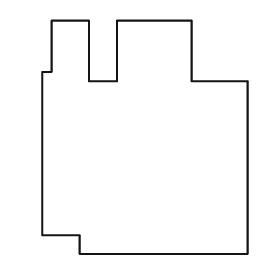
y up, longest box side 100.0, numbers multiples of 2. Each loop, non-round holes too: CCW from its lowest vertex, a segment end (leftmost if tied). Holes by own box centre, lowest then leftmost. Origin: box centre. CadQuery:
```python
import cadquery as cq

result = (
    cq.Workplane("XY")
    .moveTo(-28.0, -50.0)
    .lineTo(44.0, -50.0)
    .lineTo(44.0, 24.0)
    .lineTo(20.0, 24.0)
    .lineTo(20.0, 50.0)
    .lineTo(-12.0, 50.0)
    .lineTo(-12.0, 24.0)
    .lineTo(-24.0, 24.0)
    .lineTo(-24.0, 50.0)
    .lineTo(-40.0, 50.0)
    .lineTo(-40.0, 28.0)
    .lineTo(-44.0, 28.0)
    .lineTo(-44.0, -42.0)
    .lineTo(-28.0, -42.0)
    .close()
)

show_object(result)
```